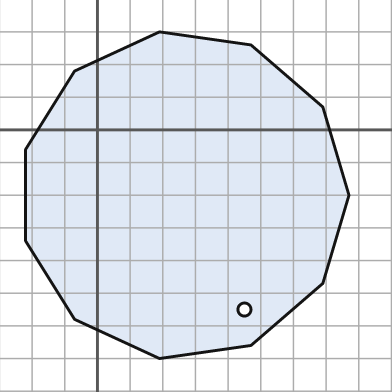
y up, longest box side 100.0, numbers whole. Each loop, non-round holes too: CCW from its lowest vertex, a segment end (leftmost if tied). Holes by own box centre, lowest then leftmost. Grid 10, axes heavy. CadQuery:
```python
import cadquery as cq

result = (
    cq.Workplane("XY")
    .moveTo(19.0, -70.0)
    .lineTo(47.0, -66.0)
    .lineTo(69.0, -47.0)
    .lineTo(77.0, -20.0)
    .lineTo(69.0, 7.0)
    .lineTo(47.0, 26.0)
    .lineTo(19.0, 30.0)
    .lineTo(-7.0, 18.0)
    .lineTo(-22.0, -6.0)
    .lineTo(-22.0, -34.0)
    .lineTo(-7.0, -58.0)
    .close()
    .moveTo(45.0, -55.0)
    .circle(2.0)
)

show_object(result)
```